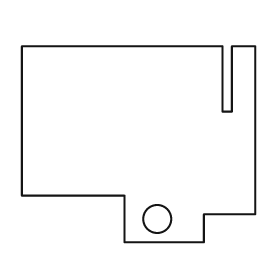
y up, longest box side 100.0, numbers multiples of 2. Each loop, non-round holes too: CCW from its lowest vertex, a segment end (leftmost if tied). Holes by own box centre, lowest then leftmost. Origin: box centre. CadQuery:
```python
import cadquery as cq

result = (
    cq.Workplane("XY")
    .moveTo(-6.0, -42.0)
    .lineTo(28.0, -42.0)
    .lineTo(28.0, -30.0)
    .lineTo(50.0, -30.0)
    .lineTo(50.0, 42.0)
    .lineTo(40.0, 42.0)
    .lineTo(40.0, 14.0)
    .lineTo(36.0, 14.0)
    .lineTo(36.0, 42.0)
    .lineTo(-50.0, 42.0)
    .lineTo(-50.0, -22.0)
    .lineTo(-6.0, -22.0)
    .close()
    .moveTo(8.0, -32.0)
    .circle(6.0)
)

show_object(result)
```